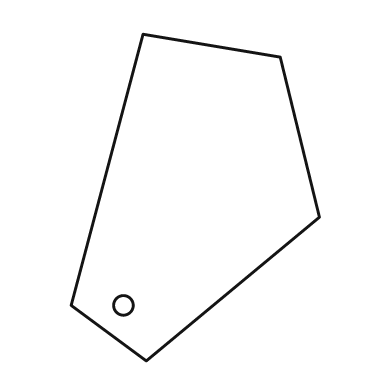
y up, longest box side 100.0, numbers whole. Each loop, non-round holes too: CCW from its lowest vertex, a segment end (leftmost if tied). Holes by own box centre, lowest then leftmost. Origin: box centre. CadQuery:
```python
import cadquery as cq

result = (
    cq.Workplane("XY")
    .moveTo(-15.0, -50.0)
    .lineTo(38.0, -6.0)
    .lineTo(26.0, 43.0)
    .lineTo(-16.0, 50.0)
    .lineTo(-38.0, -33.0)
    .close()
    .moveTo(-22.0, -33.0)
    .circle(3.0)
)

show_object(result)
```